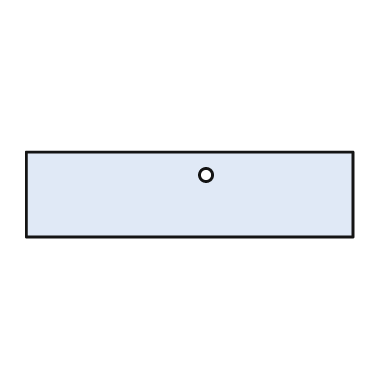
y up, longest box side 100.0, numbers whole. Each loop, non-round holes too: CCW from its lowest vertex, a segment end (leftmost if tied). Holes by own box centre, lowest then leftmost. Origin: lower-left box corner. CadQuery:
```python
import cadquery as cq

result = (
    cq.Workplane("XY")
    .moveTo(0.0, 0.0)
    .lineTo(100.0, 0.0)
    .lineTo(100.0, 26.0)
    .lineTo(0.0, 26.0)
    .close()
    .moveTo(55.0, 19.0)
    .circle(2.0)
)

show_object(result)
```